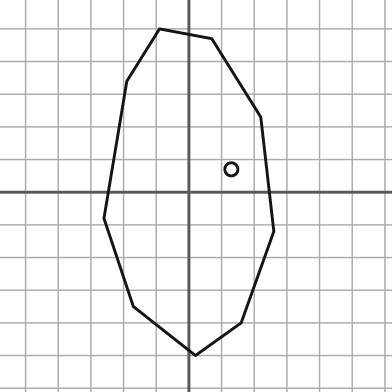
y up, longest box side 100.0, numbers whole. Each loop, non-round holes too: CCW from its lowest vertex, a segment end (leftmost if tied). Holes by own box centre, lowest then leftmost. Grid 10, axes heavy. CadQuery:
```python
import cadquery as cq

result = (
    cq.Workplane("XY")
    .moveTo(2.0, -50.0)
    .lineTo(16.0, -40.0)
    .lineTo(26.0, -12.0)
    .lineTo(22.0, 23.0)
    .lineTo(7.0, 47.0)
    .lineTo(-9.0, 50.0)
    .lineTo(-19.0, 34.0)
    .lineTo(-26.0, -8.0)
    .lineTo(-17.0, -35.0)
    .close()
    .moveTo(13.0, 7.0)
    .circle(2.0)
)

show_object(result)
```